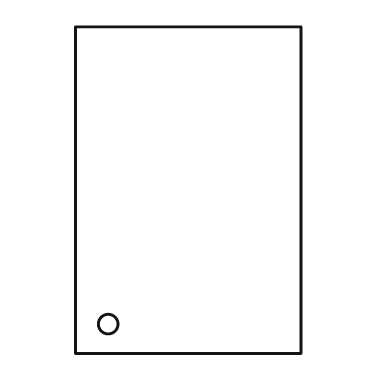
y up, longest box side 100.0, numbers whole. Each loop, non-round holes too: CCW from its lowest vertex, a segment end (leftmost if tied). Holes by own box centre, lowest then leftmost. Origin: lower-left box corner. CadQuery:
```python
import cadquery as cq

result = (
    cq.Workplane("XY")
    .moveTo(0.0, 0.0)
    .lineTo(69.0, 0.0)
    .lineTo(69.0, 100.0)
    .lineTo(0.0, 100.0)
    .close()
    .moveTo(10.0, 9.0)
    .circle(3.0)
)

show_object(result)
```